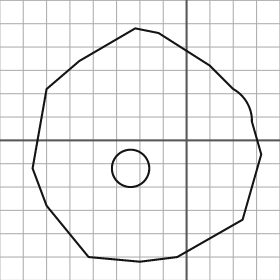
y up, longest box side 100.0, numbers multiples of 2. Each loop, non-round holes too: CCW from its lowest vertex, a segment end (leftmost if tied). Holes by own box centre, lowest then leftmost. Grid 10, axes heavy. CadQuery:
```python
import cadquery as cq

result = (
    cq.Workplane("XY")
    .moveTo(-20.0, -52.0)
    .lineTo(-4.0, -50.0)
    .lineTo(24.0, -34.0)
    .lineTo(32.0, -6.0)
    .lineTo(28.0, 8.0)
    .threePointArc((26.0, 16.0), (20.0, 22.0))
    .lineTo(10.0, 32.0)
    .lineTo(-12.0, 46.0)
    .lineTo(-22.0, 48.0)
    .lineTo(-46.0, 34.0)
    .lineTo(-60.0, 22.0)
    .lineTo(-66.0, -12.0)
    .lineTo(-60.0, -28.0)
    .lineTo(-42.0, -50.0)
    .close()
    .moveTo(-24.0, -12.0)
    .circle(8.0)
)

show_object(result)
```